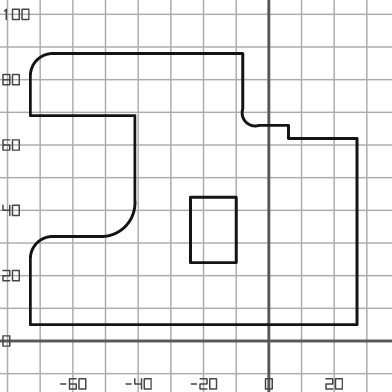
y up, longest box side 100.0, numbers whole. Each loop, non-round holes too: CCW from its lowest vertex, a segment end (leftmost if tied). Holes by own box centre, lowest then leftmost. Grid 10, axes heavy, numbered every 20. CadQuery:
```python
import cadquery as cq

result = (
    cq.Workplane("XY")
    .moveTo(-73.0, 5.0)
    .lineTo(27.0, 5.0)
    .lineTo(27.0, 62.0)
    .lineTo(6.0, 62.0)
    .lineTo(6.0, 66.0)
    .lineTo(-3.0, 66.0)
    .threePointArc((-7.0, 67.0), (-8.0, 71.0))
    .lineTo(-8.0, 88.0)
    .lineTo(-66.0, 88.0)
    .threePointArc((-71.0, 86.0), (-73.0, 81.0))
    .lineTo(-73.0, 69.0)
    .lineTo(-41.0, 69.0)
    .lineTo(-41.0, 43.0)
    .threePointArc((-44.0, 35.0), (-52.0, 32.0))
    .lineTo(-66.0, 32.0)
    .threePointArc((-71.0, 30.0), (-73.0, 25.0))
    .close()
    .moveTo(-24.0, 24.0)
    .lineTo(-10.0, 24.0)
    .lineTo(-10.0, 44.0)
    .lineTo(-24.0, 44.0)
    .close()
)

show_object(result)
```